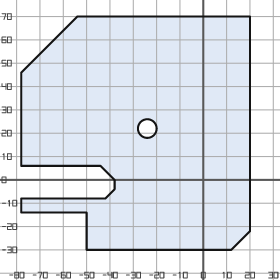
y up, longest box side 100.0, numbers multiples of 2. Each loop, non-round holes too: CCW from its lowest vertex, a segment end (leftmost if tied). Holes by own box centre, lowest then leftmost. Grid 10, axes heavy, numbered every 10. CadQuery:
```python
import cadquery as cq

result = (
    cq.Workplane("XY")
    .moveTo(-50.0, -30.0)
    .lineTo(12.0, -30.0)
    .lineTo(20.0, -22.0)
    .lineTo(20.0, 70.0)
    .lineTo(-54.0, 70.0)
    .lineTo(-78.0, 46.0)
    .lineTo(-78.0, 6.0)
    .lineTo(-44.0, 6.0)
    .lineTo(-38.0, 0.0)
    .lineTo(-38.0, -4.0)
    .lineTo(-42.0, -8.0)
    .lineTo(-78.0, -8.0)
    .lineTo(-78.0, -14.0)
    .lineTo(-50.0, -14.0)
    .close()
    .moveTo(-24.0, 22.0)
    .circle(4.0)
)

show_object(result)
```